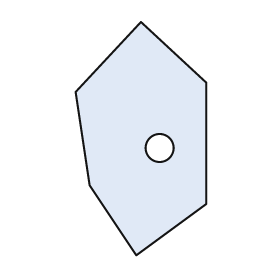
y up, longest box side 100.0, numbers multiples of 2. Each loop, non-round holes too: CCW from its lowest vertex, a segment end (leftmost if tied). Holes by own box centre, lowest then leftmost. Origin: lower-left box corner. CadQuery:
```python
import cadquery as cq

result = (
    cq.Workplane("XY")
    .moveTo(26.0, 0.0)
    .lineTo(56.0, 22.0)
    .lineTo(56.0, 74.0)
    .lineTo(28.0, 100.0)
    .lineTo(0.0, 70.0)
    .lineTo(6.0, 30.0)
    .close()
    .moveTo(36.0, 46.0)
    .circle(6.0)
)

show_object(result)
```